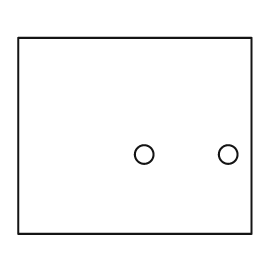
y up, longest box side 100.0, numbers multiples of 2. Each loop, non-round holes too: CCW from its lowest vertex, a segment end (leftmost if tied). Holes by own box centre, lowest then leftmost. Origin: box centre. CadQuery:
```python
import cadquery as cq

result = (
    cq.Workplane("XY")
    .moveTo(-50.0, -42.0)
    .lineTo(50.0, -42.0)
    .lineTo(50.0, 42.0)
    .lineTo(-50.0, 42.0)
    .close()
    .moveTo(4.0, -8.0)
    .circle(4.0)
    .moveTo(40.0, -8.0)
    .circle(4.0)
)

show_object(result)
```